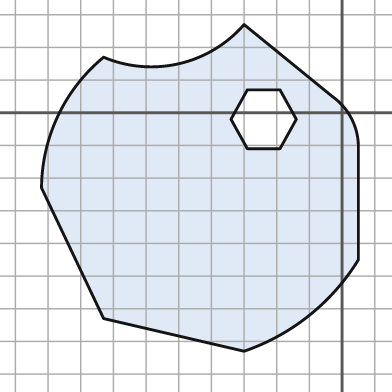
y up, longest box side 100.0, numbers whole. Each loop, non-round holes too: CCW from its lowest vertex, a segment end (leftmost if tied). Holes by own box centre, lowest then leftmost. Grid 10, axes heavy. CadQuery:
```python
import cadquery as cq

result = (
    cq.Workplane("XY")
    .moveTo(-30.0, -73.0)
    .threePointArc((-10.0, -62.0), (5.0, -45.0))
    .lineTo(5.0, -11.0)
    .threePointArc((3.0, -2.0), (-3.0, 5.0))
    .lineTo(-30.0, 27.0)
    .threePointArc((-50.0, 15.0), (-73.0, 17.0))
    .threePointArc((-87.0, -1.0), (-92.0, -23.0))
    .lineTo(-73.0, -63.0)
    .close()
    .moveTo(-29.0, -11.0)
    .lineTo(-19.0, -11.0)
    .lineTo(-14.0, -2.0)
    .lineTo(-19.0, 7.0)
    .lineTo(-29.0, 7.0)
    .lineTo(-34.0, -2.0)
    .close()
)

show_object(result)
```